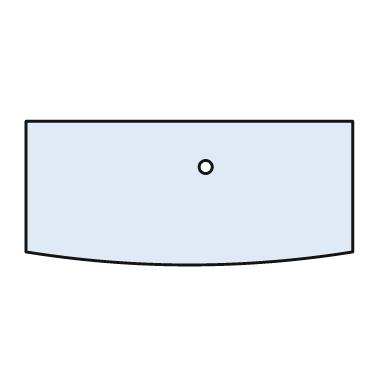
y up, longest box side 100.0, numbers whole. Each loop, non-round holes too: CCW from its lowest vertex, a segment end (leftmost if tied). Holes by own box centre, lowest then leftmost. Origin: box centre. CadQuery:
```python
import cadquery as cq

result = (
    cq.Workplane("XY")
    .moveTo(-50.0, -18.0)
    .threePointArc((0.0, -22.0), (50.0, -18.0))
    .lineTo(50.0, 22.0)
    .lineTo(-50.0, 22.0)
    .close()
    .moveTo(5.0, 8.0)
    .circle(2.0)
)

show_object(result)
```